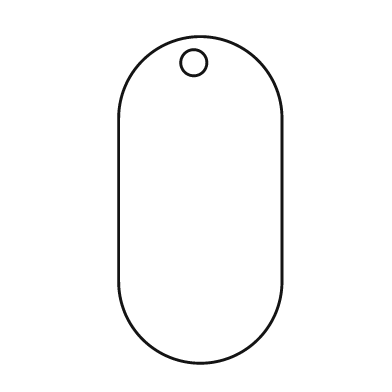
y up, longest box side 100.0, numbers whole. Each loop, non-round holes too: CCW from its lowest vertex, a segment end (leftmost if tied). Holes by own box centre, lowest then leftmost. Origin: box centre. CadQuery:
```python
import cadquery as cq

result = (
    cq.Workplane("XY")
    .moveTo(-25.0, -25.0)
    .threePointArc((0.0, -50.0), (25.0, -25.0))
    .lineTo(25.0, 25.0)
    .threePointArc((0.0, 50.0), (-25.0, 25.0))
    .close()
    .moveTo(-2.0, 42.0)
    .circle(4.0)
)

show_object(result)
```